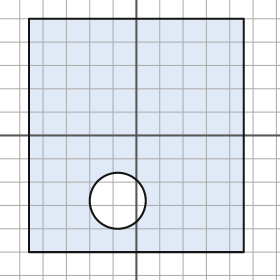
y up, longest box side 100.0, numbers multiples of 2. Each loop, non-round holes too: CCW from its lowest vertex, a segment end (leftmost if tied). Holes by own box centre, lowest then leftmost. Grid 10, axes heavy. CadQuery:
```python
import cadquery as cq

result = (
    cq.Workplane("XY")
    .moveTo(-46.0, -50.0)
    .lineTo(46.0, -50.0)
    .lineTo(46.0, 50.0)
    .lineTo(-46.0, 50.0)
    .close()
    .moveTo(-8.0, -28.0)
    .circle(12.0)
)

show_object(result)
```